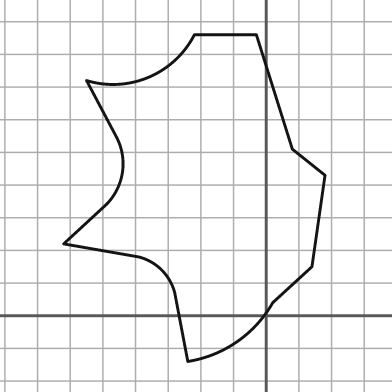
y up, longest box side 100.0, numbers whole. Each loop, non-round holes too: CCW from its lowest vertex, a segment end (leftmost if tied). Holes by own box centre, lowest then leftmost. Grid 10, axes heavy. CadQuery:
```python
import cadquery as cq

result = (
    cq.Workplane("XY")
    .moveTo(-24.0, -14.0)
    .threePointArc((-9.0, -8.0), (2.0, 4.0))
    .lineTo(14.0, 15.0)
    .lineTo(18.0, 43.0)
    .lineTo(8.0, 51.0)
    .lineTo(-3.0, 86.0)
    .lineTo(-22.0, 86.0)
    .threePointArc((-36.0, 73.0), (-55.0, 72.0))
    .lineTo(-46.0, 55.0)
    .threePointArc((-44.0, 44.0), (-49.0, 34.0))
    .lineTo(-62.0, 22.0)
    .lineTo(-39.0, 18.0)
    .threePointArc((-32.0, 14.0), (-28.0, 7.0))
    .close()
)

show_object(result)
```